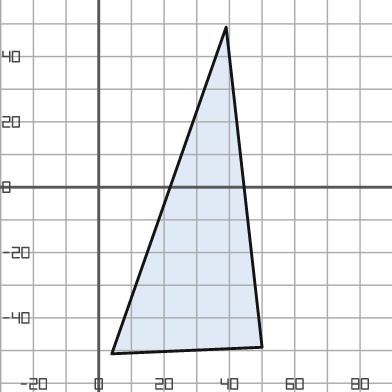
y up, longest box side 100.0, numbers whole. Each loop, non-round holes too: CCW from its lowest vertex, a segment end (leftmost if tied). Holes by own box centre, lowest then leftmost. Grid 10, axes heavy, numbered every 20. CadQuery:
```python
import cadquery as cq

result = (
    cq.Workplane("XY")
    .moveTo(4.0, -51.0)
    .lineTo(50.0, -49.0)
    .lineTo(39.0, 49.0)
    .close()
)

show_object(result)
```